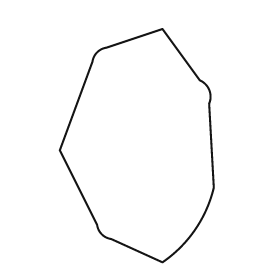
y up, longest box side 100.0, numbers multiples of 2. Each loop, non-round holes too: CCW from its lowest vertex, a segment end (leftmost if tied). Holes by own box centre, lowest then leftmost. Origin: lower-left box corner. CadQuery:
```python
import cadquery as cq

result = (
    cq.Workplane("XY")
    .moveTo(44.0, 0.0)
    .threePointArc((58.0, 14.0), (66.0, 32.0))
    .lineTo(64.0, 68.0)
    .threePointArc((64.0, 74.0), (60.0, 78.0))
    .lineTo(44.0, 100.0)
    .lineTo(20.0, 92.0)
    .threePointArc((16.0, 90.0), (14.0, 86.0))
    .lineTo(0.0, 48.0)
    .lineTo(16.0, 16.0)
    .threePointArc((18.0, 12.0), (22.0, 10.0))
    .close()
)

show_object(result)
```